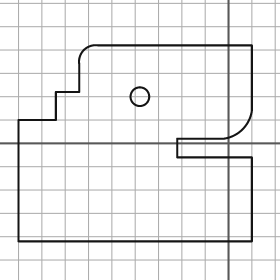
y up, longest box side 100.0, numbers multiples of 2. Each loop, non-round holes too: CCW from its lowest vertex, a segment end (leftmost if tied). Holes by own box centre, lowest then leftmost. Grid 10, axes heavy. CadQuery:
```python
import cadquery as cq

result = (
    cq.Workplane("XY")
    .moveTo(-90.0, -42.0)
    .lineTo(10.0, -42.0)
    .lineTo(10.0, -6.0)
    .lineTo(-22.0, -6.0)
    .lineTo(-22.0, 2.0)
    .lineTo(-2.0, 2.0)
    .threePointArc((6.0, 6.0), (10.0, 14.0))
    .lineTo(10.0, 42.0)
    .lineTo(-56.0, 42.0)
    .threePointArc((-62.0, 40.0), (-64.0, 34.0))
    .lineTo(-64.0, 22.0)
    .lineTo(-74.0, 22.0)
    .lineTo(-74.0, 10.0)
    .lineTo(-90.0, 10.0)
    .close()
    .moveTo(-38.0, 20.0)
    .circle(4.0)
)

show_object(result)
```